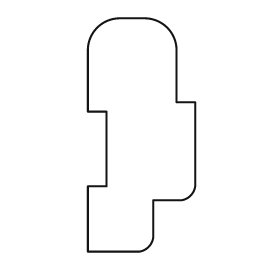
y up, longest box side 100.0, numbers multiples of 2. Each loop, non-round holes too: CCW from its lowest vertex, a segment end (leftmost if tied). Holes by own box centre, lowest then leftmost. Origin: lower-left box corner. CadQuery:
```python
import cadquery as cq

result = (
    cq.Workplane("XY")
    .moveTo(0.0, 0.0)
    .lineTo(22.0, 0.0)
    .threePointArc((26.0, 2.0), (28.0, 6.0))
    .lineTo(28.0, 22.0)
    .lineTo(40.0, 22.0)
    .threePointArc((44.0, 24.0), (46.0, 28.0))
    .lineTo(46.0, 64.0)
    .lineTo(38.0, 64.0)
    .lineTo(38.0, 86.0)
    .threePointArc((34.0, 96.0), (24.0, 100.0))
    .lineTo(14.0, 100.0)
    .threePointArc((4.0, 96.0), (0.0, 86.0))
    .lineTo(0.0, 60.0)
    .lineTo(8.0, 60.0)
    .lineTo(8.0, 28.0)
    .lineTo(0.0, 28.0)
    .close()
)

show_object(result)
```